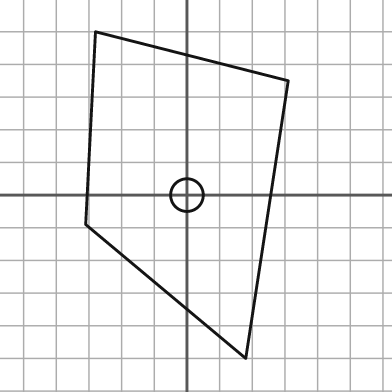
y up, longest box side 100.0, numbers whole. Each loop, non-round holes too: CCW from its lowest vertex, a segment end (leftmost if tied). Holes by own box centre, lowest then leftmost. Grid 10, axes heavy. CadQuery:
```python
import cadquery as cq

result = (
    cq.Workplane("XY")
    .moveTo(18.0, -50.0)
    .lineTo(31.0, 35.0)
    .lineTo(-28.0, 50.0)
    .lineTo(-31.0, -9.0)
    .close()
    .moveTo(0.0, 0.0)
    .circle(5.0)
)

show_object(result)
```